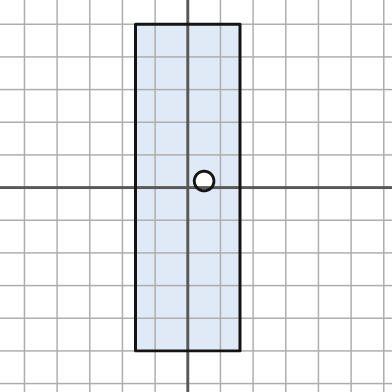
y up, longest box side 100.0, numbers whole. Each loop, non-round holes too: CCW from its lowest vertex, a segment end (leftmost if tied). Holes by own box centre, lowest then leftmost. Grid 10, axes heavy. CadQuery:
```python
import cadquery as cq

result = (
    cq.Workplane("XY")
    .moveTo(-16.0, -50.0)
    .lineTo(16.0, -50.0)
    .lineTo(16.0, 50.0)
    .lineTo(-16.0, 50.0)
    .close()
    .moveTo(5.0, 2.0)
    .circle(3.0)
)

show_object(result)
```